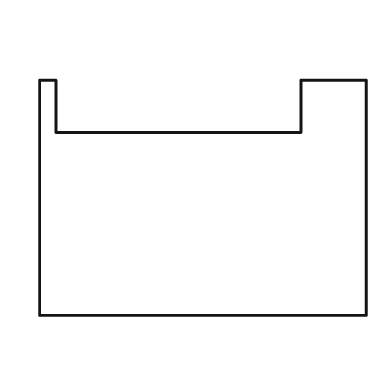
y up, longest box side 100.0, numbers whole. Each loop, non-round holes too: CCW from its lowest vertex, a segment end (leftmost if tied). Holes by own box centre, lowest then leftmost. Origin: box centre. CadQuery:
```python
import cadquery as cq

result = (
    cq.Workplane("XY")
    .moveTo(-50.0, -36.0)
    .lineTo(50.0, -36.0)
    .lineTo(50.0, 36.0)
    .lineTo(30.0, 36.0)
    .lineTo(30.0, 20.0)
    .lineTo(-45.0, 20.0)
    .lineTo(-45.0, 36.0)
    .lineTo(-50.0, 36.0)
    .close()
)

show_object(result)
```